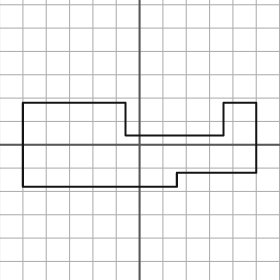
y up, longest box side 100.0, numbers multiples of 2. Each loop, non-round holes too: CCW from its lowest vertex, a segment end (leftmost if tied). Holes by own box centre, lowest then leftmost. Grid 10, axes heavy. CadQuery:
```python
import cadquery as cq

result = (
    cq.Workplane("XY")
    .moveTo(-50.0, -18.0)
    .lineTo(16.0, -18.0)
    .lineTo(16.0, -12.0)
    .lineTo(50.0, -12.0)
    .lineTo(50.0, 18.0)
    .lineTo(36.0, 18.0)
    .lineTo(36.0, 4.0)
    .lineTo(-6.0, 4.0)
    .lineTo(-6.0, 18.0)
    .lineTo(-50.0, 18.0)
    .close()
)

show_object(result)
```